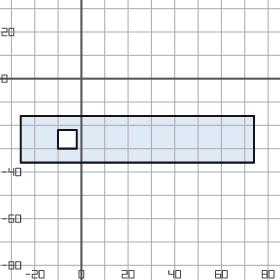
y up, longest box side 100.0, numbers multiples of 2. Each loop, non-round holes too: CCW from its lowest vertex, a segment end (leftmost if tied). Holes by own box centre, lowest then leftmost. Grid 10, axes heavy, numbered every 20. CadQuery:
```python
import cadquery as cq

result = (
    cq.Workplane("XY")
    .moveTo(-26.0, -36.0)
    .lineTo(74.0, -36.0)
    .lineTo(74.0, -16.0)
    .lineTo(-26.0, -16.0)
    .close()
    .moveTo(-10.0, -30.0)
    .lineTo(-2.0, -30.0)
    .lineTo(-2.0, -22.0)
    .lineTo(-10.0, -22.0)
    .close()
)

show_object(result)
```